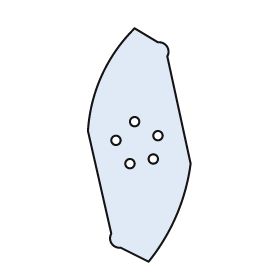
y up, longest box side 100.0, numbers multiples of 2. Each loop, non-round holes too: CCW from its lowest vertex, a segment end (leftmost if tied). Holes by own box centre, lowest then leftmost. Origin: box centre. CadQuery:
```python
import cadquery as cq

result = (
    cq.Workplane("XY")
    .moveTo(4.0, -50.0)
    .threePointArc((16.0, -30.0), (22.0, -8.0))
    .lineTo(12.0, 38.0)
    .threePointArc((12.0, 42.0), (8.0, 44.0))
    .lineTo(-2.0, 50.0)
    .threePointArc((-16.0, 30.0), (-22.0, 6.0))
    .lineTo(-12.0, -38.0)
    .threePointArc((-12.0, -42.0), (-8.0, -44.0))
    .close()
    .moveTo(-4.0, -8.0)
    .circle(2.0)
    .moveTo(6.0, -6.0)
    .circle(2.0)
    .moveTo(-10.0, 2.0)
    .circle(2.0)
    .moveTo(8.0, 4.0)
    .circle(2.0)
    .moveTo(-2.0, 10.0)
    .circle(2.0)
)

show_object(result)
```